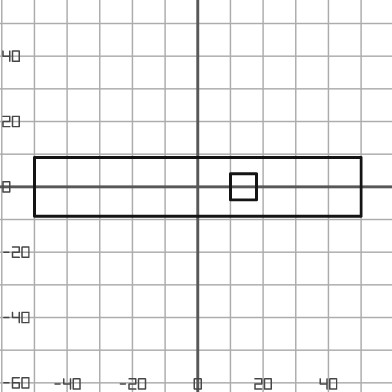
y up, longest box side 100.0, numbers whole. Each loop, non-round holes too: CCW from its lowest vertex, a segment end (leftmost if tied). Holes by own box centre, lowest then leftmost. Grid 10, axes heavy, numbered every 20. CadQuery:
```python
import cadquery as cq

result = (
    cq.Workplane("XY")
    .moveTo(-50.0, -9.0)
    .lineTo(50.0, -9.0)
    .lineTo(50.0, 9.0)
    .lineTo(-50.0, 9.0)
    .close()
    .moveTo(10.0, -4.0)
    .lineTo(18.0, -4.0)
    .lineTo(18.0, 4.0)
    .lineTo(10.0, 4.0)
    .close()
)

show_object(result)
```